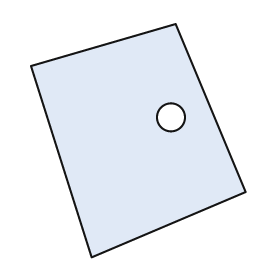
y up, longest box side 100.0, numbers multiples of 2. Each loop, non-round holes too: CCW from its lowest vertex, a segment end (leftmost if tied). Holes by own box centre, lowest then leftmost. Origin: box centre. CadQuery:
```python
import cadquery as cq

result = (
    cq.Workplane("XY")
    .moveTo(-20.0, -50.0)
    .lineTo(46.0, -22.0)
    .lineTo(16.0, 50.0)
    .lineTo(-46.0, 32.0)
    .close()
    .moveTo(14.0, 10.0)
    .circle(6.0)
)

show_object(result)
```